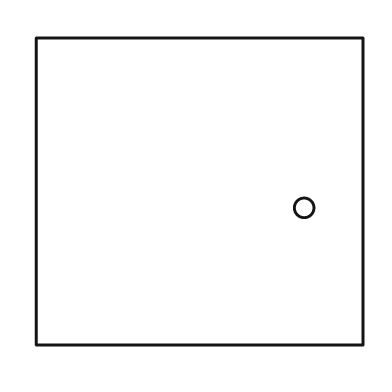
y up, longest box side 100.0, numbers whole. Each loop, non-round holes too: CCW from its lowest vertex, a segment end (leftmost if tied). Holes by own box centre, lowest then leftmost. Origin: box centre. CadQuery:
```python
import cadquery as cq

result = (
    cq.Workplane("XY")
    .moveTo(-50.0, -47.0)
    .lineTo(50.0, -47.0)
    .lineTo(50.0, 47.0)
    .lineTo(-50.0, 47.0)
    .close()
    .moveTo(32.0, -5.0)
    .circle(3.0)
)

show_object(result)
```